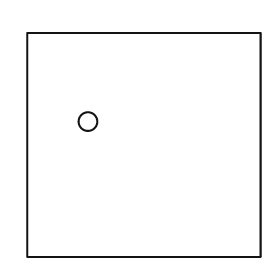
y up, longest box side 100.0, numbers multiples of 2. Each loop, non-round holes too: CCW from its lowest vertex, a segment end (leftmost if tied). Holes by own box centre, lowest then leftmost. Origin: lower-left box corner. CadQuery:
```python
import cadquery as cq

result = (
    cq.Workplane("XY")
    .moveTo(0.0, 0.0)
    .lineTo(100.0, 0.0)
    .lineTo(100.0, 96.0)
    .lineTo(0.0, 96.0)
    .close()
    .moveTo(26.0, 58.0)
    .circle(4.0)
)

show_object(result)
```